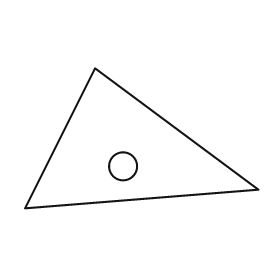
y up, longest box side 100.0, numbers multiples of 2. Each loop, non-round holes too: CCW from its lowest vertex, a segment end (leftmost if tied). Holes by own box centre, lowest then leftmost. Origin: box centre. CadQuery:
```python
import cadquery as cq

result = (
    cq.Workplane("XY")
    .moveTo(-50.0, -30.0)
    .lineTo(50.0, -22.0)
    .lineTo(-20.0, 30.0)
    .close()
    .moveTo(-8.0, -12.0)
    .circle(6.0)
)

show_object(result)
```